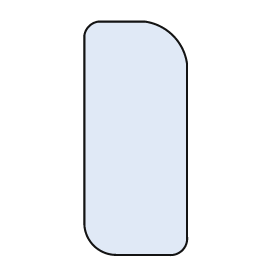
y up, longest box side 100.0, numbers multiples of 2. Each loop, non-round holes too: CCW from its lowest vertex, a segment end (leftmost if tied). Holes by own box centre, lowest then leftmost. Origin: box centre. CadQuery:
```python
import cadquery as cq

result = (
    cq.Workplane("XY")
    .moveTo(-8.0, -50.0)
    .lineTo(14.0, -50.0)
    .threePointArc((20.0, -48.0), (22.0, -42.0))
    .lineTo(22.0, 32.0)
    .threePointArc((16.0, 44.0), (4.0, 50.0))
    .lineTo(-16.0, 50.0)
    .threePointArc((-20.0, 48.0), (-22.0, 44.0))
    .lineTo(-22.0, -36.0)
    .threePointArc((-18.0, -46.0), (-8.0, -50.0))
    .close()
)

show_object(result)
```